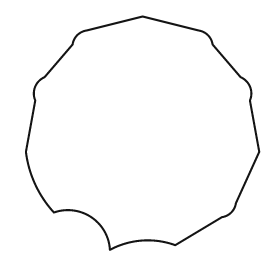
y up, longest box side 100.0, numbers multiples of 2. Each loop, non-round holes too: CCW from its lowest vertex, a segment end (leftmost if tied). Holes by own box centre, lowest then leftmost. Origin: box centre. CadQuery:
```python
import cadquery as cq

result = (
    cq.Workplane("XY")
    .moveTo(-14.0, -50.0)
    .threePointArc((0.0, -46.0), (14.0, -48.0))
    .lineTo(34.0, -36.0)
    .threePointArc((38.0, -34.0), (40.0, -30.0))
    .lineTo(50.0, -8.0)
    .lineTo(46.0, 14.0)
    .threePointArc((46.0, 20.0), (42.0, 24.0))
    .lineTo(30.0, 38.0)
    .threePointArc((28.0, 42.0), (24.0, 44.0))
    .lineTo(0.0, 50.0)
    .lineTo(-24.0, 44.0)
    .threePointArc((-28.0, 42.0), (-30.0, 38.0))
    .lineTo(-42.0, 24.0)
    .threePointArc((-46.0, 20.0), (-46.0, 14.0))
    .lineTo(-50.0, -8.0)
    .threePointArc((-46.0, -22.0), (-38.0, -34.0))
    .threePointArc((-22.0, -36.0), (-14.0, -50.0))
    .close()
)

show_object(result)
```